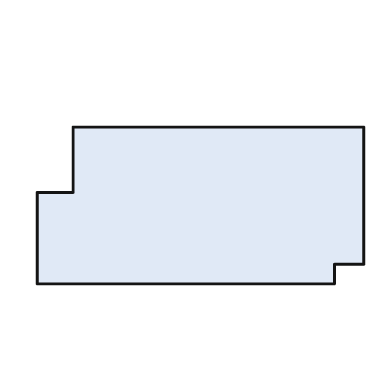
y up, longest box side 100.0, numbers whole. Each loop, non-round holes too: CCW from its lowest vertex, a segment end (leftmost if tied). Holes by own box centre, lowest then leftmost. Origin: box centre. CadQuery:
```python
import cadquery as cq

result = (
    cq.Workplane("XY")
    .moveTo(-50.0, -24.0)
    .lineTo(41.0, -24.0)
    .lineTo(41.0, -18.0)
    .lineTo(50.0, -18.0)
    .lineTo(50.0, 24.0)
    .lineTo(-39.0, 24.0)
    .lineTo(-39.0, 4.0)
    .lineTo(-50.0, 4.0)
    .close()
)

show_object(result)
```